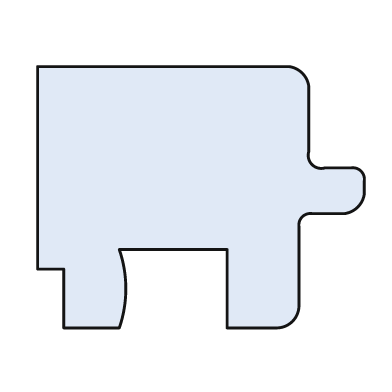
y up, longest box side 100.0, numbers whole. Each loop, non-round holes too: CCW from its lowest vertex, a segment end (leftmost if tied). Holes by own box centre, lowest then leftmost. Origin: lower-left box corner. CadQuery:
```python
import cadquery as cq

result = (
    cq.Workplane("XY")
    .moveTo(8.0, 0.0)
    .lineTo(25.0, 0.0)
    .threePointArc((27.0, 12.0), (25.0, 24.0))
    .lineTo(58.0, 24.0)
    .lineTo(58.0, 0.0)
    .lineTo(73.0, 0.0)
    .threePointArc((78.0, 2.0), (80.0, 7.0))
    .lineTo(80.0, 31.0)
    .threePointArc((81.0, 34.0), (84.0, 35.0))
    .lineTo(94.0, 35.0)
    .threePointArc((98.0, 37.0), (100.0, 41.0))
    .lineTo(100.0, 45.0)
    .threePointArc((99.0, 48.0), (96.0, 49.0))
    .lineTo(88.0, 49.0)
    .threePointArc((84.0, 50.0), (83.0, 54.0))
    .lineTo(83.0, 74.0)
    .threePointArc((81.0, 78.0), (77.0, 80.0))
    .lineTo(0.0, 80.0)
    .lineTo(0.0, 18.0)
    .lineTo(8.0, 18.0)
    .close()
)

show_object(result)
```